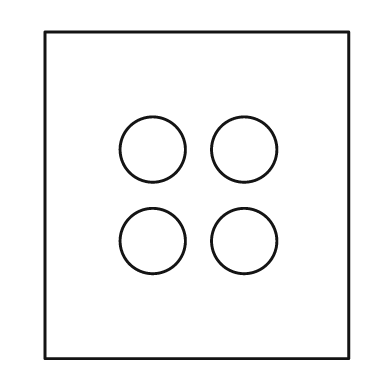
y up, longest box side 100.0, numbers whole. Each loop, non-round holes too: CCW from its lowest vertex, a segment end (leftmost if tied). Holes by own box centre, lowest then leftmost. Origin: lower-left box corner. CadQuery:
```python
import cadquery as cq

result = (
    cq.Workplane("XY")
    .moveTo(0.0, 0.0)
    .lineTo(93.0, 0.0)
    .lineTo(93.0, 100.0)
    .lineTo(0.0, 100.0)
    .close()
    .moveTo(33.0, 36.0)
    .circle(10.0)
    .moveTo(61.0, 36.0)
    .circle(10.0)
    .moveTo(33.0, 64.0)
    .circle(10.0)
    .moveTo(61.0, 64.0)
    .circle(10.0)
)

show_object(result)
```